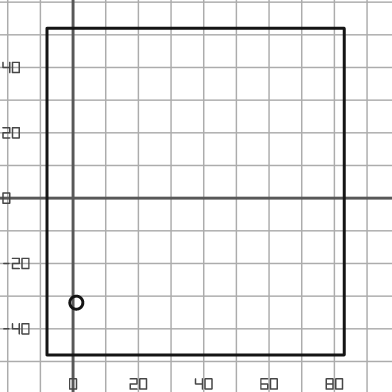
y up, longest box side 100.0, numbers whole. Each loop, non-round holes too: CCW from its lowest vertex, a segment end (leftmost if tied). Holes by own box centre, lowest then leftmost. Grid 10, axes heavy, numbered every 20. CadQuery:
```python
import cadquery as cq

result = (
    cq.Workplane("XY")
    .moveTo(-8.0, -48.0)
    .lineTo(83.0, -48.0)
    .lineTo(83.0, 52.0)
    .lineTo(-8.0, 52.0)
    .close()
    .moveTo(1.0, -32.0)
    .circle(2.0)
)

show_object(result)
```